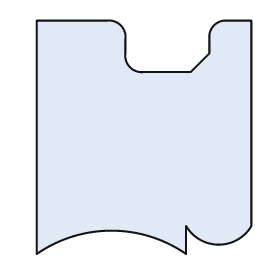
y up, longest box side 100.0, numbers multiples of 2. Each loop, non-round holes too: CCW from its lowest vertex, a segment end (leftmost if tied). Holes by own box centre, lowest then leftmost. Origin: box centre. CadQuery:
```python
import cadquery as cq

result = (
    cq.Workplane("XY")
    .moveTo(-46.0, -50.0)
    .threePointArc((-14.0, -40.0), (18.0, -50.0))
    .lineTo(18.0, -38.0)
    .threePointArc((32.0, -46.0), (46.0, -38.0))
    .lineTo(46.0, 50.0)
    .lineTo(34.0, 50.0)
    .threePointArc((30.0, 48.0), (28.0, 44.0))
    .lineTo(28.0, 36.0)
    .lineTo(20.0, 28.0)
    .lineTo(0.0, 28.0)
    .threePointArc((-6.0, 30.0), (-8.0, 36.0))
    .lineTo(-8.0, 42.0)
    .threePointArc((-10.0, 48.0), (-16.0, 50.0))
    .lineTo(-46.0, 50.0)
    .close()
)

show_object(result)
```